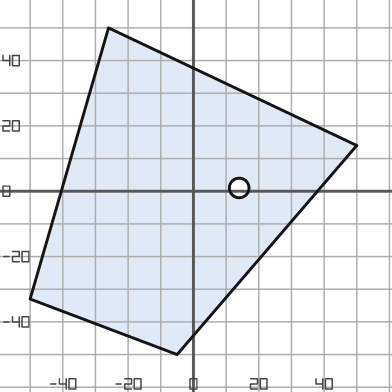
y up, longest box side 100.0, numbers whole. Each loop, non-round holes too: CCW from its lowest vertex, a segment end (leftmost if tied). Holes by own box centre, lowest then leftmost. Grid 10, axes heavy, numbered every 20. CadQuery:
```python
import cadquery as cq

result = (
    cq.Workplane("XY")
    .moveTo(-5.0, -50.0)
    .lineTo(50.0, 14.0)
    .lineTo(-26.0, 50.0)
    .lineTo(-50.0, -33.0)
    .close()
    .moveTo(14.0, 1.0)
    .circle(3.0)
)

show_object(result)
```